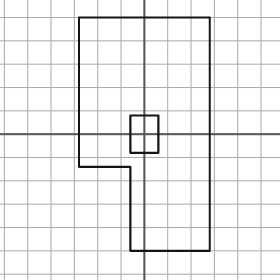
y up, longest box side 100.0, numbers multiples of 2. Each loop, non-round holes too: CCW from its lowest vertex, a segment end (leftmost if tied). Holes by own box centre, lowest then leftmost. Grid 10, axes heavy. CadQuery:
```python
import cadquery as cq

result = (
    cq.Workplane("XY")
    .moveTo(-6.0, -50.0)
    .lineTo(28.0, -50.0)
    .lineTo(28.0, 50.0)
    .lineTo(-28.0, 50.0)
    .lineTo(-28.0, -14.0)
    .lineTo(-6.0, -14.0)
    .close()
    .moveTo(-6.0, -8.0)
    .lineTo(6.0, -8.0)
    .lineTo(6.0, 8.0)
    .lineTo(-6.0, 8.0)
    .close()
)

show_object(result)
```